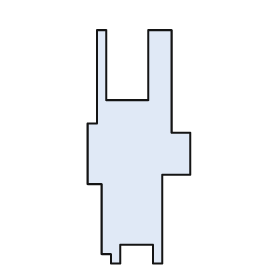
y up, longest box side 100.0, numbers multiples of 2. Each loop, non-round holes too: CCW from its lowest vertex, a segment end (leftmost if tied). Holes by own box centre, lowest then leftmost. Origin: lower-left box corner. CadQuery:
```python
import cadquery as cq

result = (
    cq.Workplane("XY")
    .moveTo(10.0, 0.0)
    .lineTo(14.0, 0.0)
    .lineTo(14.0, 8.0)
    .lineTo(28.0, 8.0)
    .lineTo(28.0, 0.0)
    .lineTo(32.0, 0.0)
    .lineTo(32.0, 38.0)
    .lineTo(44.0, 38.0)
    .lineTo(44.0, 56.0)
    .lineTo(36.0, 56.0)
    .lineTo(36.0, 100.0)
    .lineTo(26.0, 100.0)
    .lineTo(26.0, 70.0)
    .lineTo(8.0, 70.0)
    .lineTo(8.0, 100.0)
    .lineTo(4.0, 100.0)
    .lineTo(4.0, 60.0)
    .lineTo(0.0, 60.0)
    .lineTo(0.0, 34.0)
    .lineTo(6.0, 34.0)
    .lineTo(6.0, 4.0)
    .lineTo(10.0, 4.0)
    .close()
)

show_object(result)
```